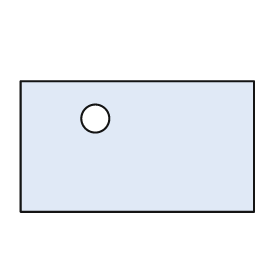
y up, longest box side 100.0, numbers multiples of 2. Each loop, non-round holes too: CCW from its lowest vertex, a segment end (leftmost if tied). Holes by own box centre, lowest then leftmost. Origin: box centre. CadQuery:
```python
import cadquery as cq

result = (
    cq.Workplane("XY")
    .moveTo(-50.0, -28.0)
    .lineTo(50.0, -28.0)
    .lineTo(50.0, 28.0)
    .lineTo(-50.0, 28.0)
    .close()
    .moveTo(-18.0, 12.0)
    .circle(6.0)
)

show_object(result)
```